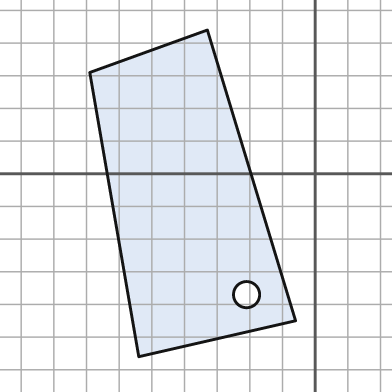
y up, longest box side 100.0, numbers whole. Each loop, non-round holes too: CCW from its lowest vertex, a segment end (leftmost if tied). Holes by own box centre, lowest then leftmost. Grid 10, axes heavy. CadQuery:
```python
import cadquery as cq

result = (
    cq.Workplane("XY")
    .moveTo(-54.0, -56.0)
    .lineTo(-6.0, -45.0)
    .lineTo(-33.0, 44.0)
    .lineTo(-69.0, 31.0)
    .close()
    .moveTo(-21.0, -37.0)
    .circle(4.0)
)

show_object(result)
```